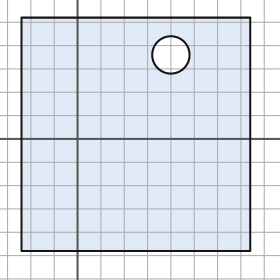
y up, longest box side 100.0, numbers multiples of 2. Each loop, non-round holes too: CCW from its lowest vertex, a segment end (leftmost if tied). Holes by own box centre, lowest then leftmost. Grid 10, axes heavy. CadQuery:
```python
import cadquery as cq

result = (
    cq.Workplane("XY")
    .moveTo(-24.0, -48.0)
    .lineTo(74.0, -48.0)
    .lineTo(74.0, 52.0)
    .lineTo(-24.0, 52.0)
    .close()
    .moveTo(40.0, 36.0)
    .circle(8.0)
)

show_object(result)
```